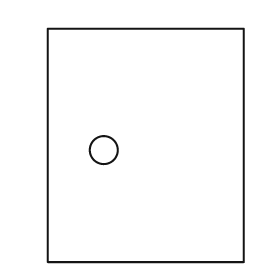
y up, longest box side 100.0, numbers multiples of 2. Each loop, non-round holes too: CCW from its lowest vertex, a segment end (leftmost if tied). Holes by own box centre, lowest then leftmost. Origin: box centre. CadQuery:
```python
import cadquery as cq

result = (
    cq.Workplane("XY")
    .moveTo(-42.0, -50.0)
    .lineTo(42.0, -50.0)
    .lineTo(42.0, 50.0)
    .lineTo(-42.0, 50.0)
    .close()
    .moveTo(-18.0, -2.0)
    .circle(6.0)
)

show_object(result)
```